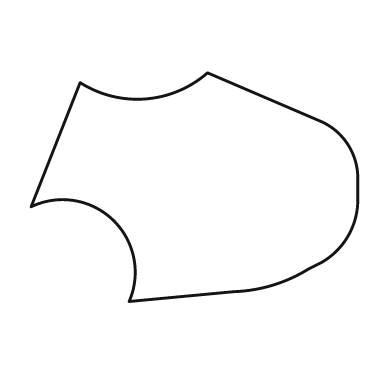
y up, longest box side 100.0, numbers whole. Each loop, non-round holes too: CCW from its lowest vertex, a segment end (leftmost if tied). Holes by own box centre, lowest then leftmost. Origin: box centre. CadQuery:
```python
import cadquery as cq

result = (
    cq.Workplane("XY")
    .moveTo(-20.0, -35.0)
    .lineTo(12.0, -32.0)
    .threePointArc((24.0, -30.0), (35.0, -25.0))
    .lineTo(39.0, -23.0)
    .threePointArc((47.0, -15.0), (50.0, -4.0))
    .lineTo(50.0, 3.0)
    .threePointArc((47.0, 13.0), (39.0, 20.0))
    .lineTo(4.0, 35.0)
    .threePointArc((-15.0, 27.0), (-35.0, 32.0))
    .lineTo(-50.0, -6.0)
    .threePointArc((-25.0, -10.0), (-20.0, -35.0))
    .close()
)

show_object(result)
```